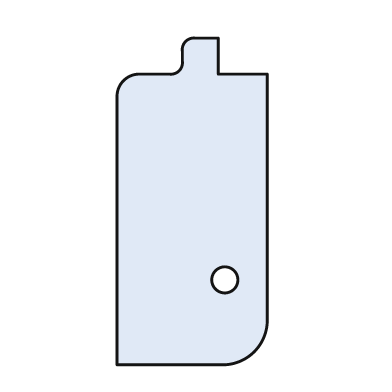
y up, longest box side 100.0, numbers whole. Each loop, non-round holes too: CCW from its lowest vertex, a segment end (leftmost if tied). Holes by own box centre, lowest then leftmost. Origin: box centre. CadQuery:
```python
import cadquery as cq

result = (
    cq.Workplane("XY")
    .moveTo(-23.0, -50.0)
    .lineTo(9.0, -50.0)
    .threePointArc((19.0, -46.0), (23.0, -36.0))
    .lineTo(23.0, 39.0)
    .lineTo(8.0, 39.0)
    .lineTo(8.0, 50.0)
    .lineTo(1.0, 50.0)
    .threePointArc((-2.0, 49.0), (-3.0, 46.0))
    .lineTo(-3.0, 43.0)
    .threePointArc((-4.0, 40.0), (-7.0, 39.0))
    .lineTo(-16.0, 39.0)
    .threePointArc((-21.0, 37.0), (-23.0, 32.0))
    .close()
    .moveTo(10.0, -24.0)
    .circle(4.0)
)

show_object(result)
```